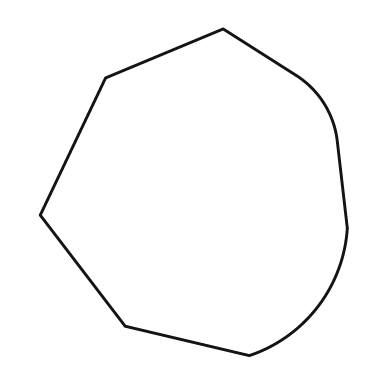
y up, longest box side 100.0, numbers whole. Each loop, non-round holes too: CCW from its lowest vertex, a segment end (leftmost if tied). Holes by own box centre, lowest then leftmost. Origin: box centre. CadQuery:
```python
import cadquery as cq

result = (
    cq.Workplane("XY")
    .moveTo(17.0, -50.0)
    .threePointArc((38.0, -35.0), (47.0, -11.0))
    .lineTo(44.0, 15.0)
    .threePointArc((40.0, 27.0), (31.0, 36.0))
    .lineTo(9.0, 50.0)
    .lineTo(-27.0, 35.0)
    .lineTo(-47.0, -7.0)
    .lineTo(-21.0, -41.0)
    .close()
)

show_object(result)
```